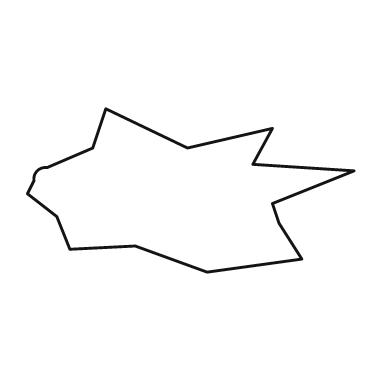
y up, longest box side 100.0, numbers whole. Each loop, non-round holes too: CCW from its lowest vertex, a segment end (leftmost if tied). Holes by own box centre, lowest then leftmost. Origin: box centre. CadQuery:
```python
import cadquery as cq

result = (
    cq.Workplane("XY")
    .moveTo(5.0, -25.0)
    .lineTo(34.0, -21.0)
    .lineTo(27.0, -10.0)
    .lineTo(25.0, -4.0)
    .lineTo(50.0, 6.0)
    .lineTo(19.0, 8.0)
    .lineTo(25.0, 19.0)
    .lineTo(-1.0, 13.0)
    .lineTo(-26.0, 25.0)
    .lineTo(-30.0, 13.0)
    .lineTo(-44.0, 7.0)
    .threePointArc((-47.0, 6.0), (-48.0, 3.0))
    .lineTo(-50.0, -1.0)
    .lineTo(-41.0, -8.0)
    .lineTo(-37.0, -18.0)
    .lineTo(-17.0, -17.0)
    .close()
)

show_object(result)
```